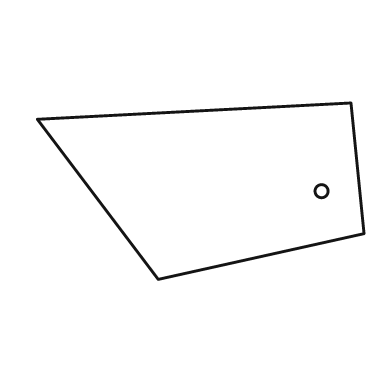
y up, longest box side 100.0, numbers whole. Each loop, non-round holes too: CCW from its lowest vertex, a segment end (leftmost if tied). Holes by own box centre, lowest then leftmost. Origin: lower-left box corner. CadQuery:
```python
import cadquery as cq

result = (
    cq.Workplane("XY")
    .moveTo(37.0, 0.0)
    .lineTo(100.0, 14.0)
    .lineTo(96.0, 54.0)
    .lineTo(0.0, 49.0)
    .close()
    .moveTo(87.0, 27.0)
    .circle(2.0)
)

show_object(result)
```